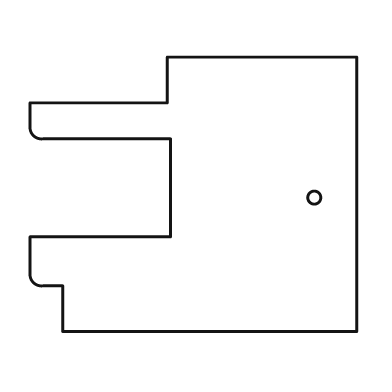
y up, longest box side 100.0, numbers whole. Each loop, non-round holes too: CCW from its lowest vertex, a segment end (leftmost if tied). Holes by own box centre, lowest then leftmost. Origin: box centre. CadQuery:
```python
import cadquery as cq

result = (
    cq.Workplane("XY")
    .moveTo(-40.0, -42.0)
    .lineTo(50.0, -42.0)
    .lineTo(50.0, 42.0)
    .lineTo(-8.0, 42.0)
    .lineTo(-8.0, 28.0)
    .lineTo(-50.0, 28.0)
    .lineTo(-50.0, 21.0)
    .threePointArc((-49.0, 18.0), (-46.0, 17.0))
    .lineTo(-7.0, 17.0)
    .lineTo(-7.0, -13.0)
    .lineTo(-50.0, -13.0)
    .lineTo(-50.0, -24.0)
    .threePointArc((-49.0, -27.0), (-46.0, -28.0))
    .lineTo(-40.0, -28.0)
    .close()
    .moveTo(37.0, -1.0)
    .circle(2.0)
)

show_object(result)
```